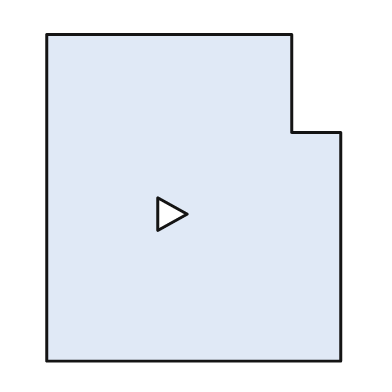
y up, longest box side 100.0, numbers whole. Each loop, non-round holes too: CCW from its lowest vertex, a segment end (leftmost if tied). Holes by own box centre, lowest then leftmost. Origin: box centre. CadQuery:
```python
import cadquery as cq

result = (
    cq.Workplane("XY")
    .moveTo(-45.0, -50.0)
    .lineTo(45.0, -50.0)
    .lineTo(45.0, 20.0)
    .lineTo(30.0, 20.0)
    .lineTo(30.0, 50.0)
    .lineTo(-45.0, 50.0)
    .close()
    .moveTo(-11.0, -10.0)
    .lineTo(-2.0, -5.0)
    .lineTo(-11.0, 0.0)
    .close()
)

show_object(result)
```